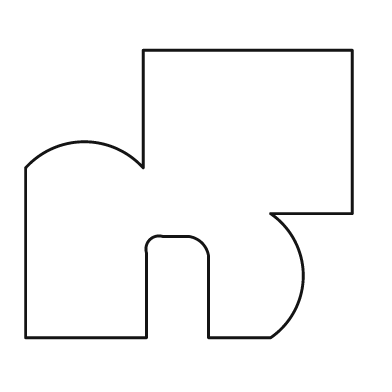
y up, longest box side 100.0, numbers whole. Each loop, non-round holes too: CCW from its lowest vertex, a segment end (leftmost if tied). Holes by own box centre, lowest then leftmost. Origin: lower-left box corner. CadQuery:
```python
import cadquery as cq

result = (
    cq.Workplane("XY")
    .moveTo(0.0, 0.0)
    .lineTo(37.0, 0.0)
    .lineTo(37.0, 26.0)
    .threePointArc((38.0, 30.0), (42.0, 31.0))
    .lineTo(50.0, 31.0)
    .threePointArc((54.0, 29.0), (56.0, 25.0))
    .lineTo(56.0, 0.0)
    .lineTo(75.0, 0.0)
    .threePointArc((85.0, 19.0), (75.0, 38.0))
    .lineTo(100.0, 38.0)
    .lineTo(100.0, 88.0)
    .lineTo(36.0, 88.0)
    .lineTo(36.0, 52.0)
    .threePointArc((18.0, 60.0), (0.0, 52.0))
    .close()
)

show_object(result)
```